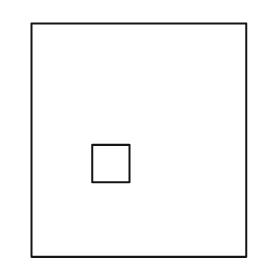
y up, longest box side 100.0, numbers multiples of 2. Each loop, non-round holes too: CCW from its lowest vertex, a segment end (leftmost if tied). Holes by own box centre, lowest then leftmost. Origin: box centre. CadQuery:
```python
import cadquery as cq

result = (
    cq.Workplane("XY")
    .moveTo(-46.0, -50.0)
    .lineTo(46.0, -50.0)
    .lineTo(46.0, 50.0)
    .lineTo(-46.0, 50.0)
    .close()
    .moveTo(-20.0, -18.0)
    .lineTo(-4.0, -18.0)
    .lineTo(-4.0, -2.0)
    .lineTo(-20.0, -2.0)
    .close()
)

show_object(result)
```